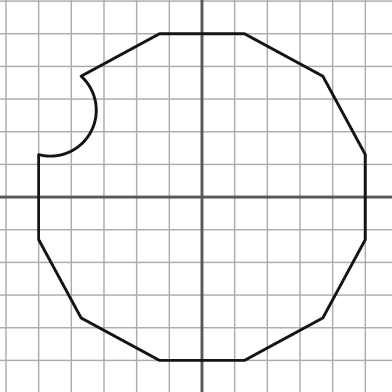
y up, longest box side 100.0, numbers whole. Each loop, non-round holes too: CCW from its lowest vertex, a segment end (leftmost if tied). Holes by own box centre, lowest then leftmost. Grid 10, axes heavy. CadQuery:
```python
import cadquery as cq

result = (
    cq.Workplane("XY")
    .moveTo(-13.0, -50.0)
    .lineTo(13.0, -50.0)
    .lineTo(37.0, -37.0)
    .lineTo(50.0, -13.0)
    .lineTo(50.0, 13.0)
    .lineTo(37.0, 37.0)
    .lineTo(13.0, 50.0)
    .lineTo(-13.0, 50.0)
    .lineTo(-37.0, 37.0)
    .threePointArc((-34.0, 20.0), (-50.0, 13.0))
    .lineTo(-50.0, -13.0)
    .lineTo(-37.0, -37.0)
    .close()
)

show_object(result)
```